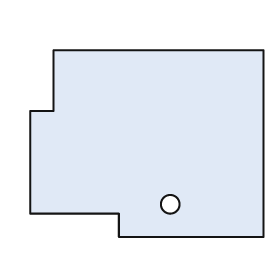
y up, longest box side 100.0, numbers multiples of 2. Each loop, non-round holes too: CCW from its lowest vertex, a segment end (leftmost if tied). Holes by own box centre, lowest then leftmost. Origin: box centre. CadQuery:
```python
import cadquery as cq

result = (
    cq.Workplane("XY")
    .moveTo(-12.0, -40.0)
    .lineTo(50.0, -40.0)
    .lineTo(50.0, 40.0)
    .lineTo(-40.0, 40.0)
    .lineTo(-40.0, 14.0)
    .lineTo(-50.0, 14.0)
    .lineTo(-50.0, -30.0)
    .lineTo(-12.0, -30.0)
    .close()
    .moveTo(10.0, -26.0)
    .circle(4.0)
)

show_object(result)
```